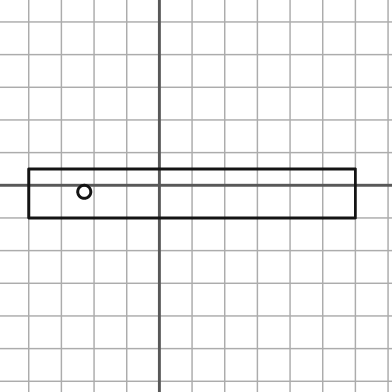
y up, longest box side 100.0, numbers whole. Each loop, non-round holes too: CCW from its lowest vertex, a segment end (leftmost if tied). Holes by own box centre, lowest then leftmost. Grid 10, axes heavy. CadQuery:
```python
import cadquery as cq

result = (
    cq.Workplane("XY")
    .moveTo(-40.0, -10.0)
    .lineTo(60.0, -10.0)
    .lineTo(60.0, 5.0)
    .lineTo(-40.0, 5.0)
    .close()
    .moveTo(-23.0, -2.0)
    .circle(2.0)
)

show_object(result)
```